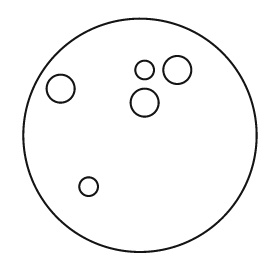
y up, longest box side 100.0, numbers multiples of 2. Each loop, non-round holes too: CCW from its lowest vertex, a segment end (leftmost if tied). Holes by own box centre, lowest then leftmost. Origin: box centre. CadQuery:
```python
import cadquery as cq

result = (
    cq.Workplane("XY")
    .moveTo(0.0, 0.0)
    .circle(50.0)
    .moveTo(-22.0, -22.0)
    .circle(4.0)
    .moveTo(2.0, 14.0)
    .circle(6.0)
    .moveTo(-34.0, 20.0)
    .circle(6.0)
    .moveTo(2.0, 28.0)
    .circle(4.0)
    .moveTo(16.0, 28.0)
    .circle(6.0)
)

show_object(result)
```